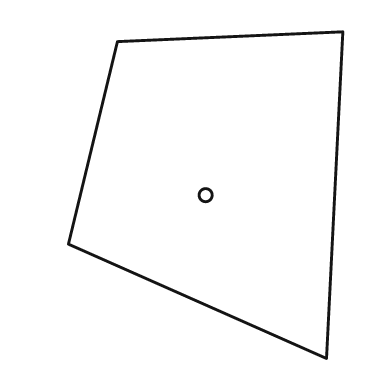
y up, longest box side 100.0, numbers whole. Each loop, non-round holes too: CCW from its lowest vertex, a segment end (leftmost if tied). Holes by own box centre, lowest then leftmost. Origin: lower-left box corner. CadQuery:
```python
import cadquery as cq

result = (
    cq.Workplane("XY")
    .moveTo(79.0, 0.0)
    .lineTo(84.0, 100.0)
    .lineTo(15.0, 97.0)
    .lineTo(0.0, 35.0)
    .close()
    .moveTo(42.0, 50.0)
    .circle(2.0)
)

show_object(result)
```